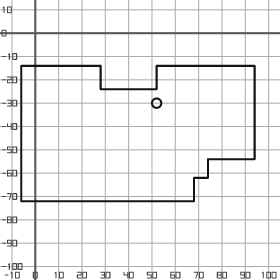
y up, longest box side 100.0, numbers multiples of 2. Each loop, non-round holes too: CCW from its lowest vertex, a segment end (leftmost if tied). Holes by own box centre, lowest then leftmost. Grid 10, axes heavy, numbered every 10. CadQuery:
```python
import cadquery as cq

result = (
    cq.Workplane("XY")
    .moveTo(-6.0, -72.0)
    .lineTo(68.0, -72.0)
    .lineTo(68.0, -62.0)
    .lineTo(74.0, -62.0)
    .lineTo(74.0, -54.0)
    .lineTo(94.0, -54.0)
    .lineTo(94.0, -14.0)
    .lineTo(52.0, -14.0)
    .lineTo(52.0, -24.0)
    .lineTo(28.0, -24.0)
    .lineTo(28.0, -14.0)
    .lineTo(-6.0, -14.0)
    .close()
    .moveTo(52.0, -30.0)
    .circle(2.0)
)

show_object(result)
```